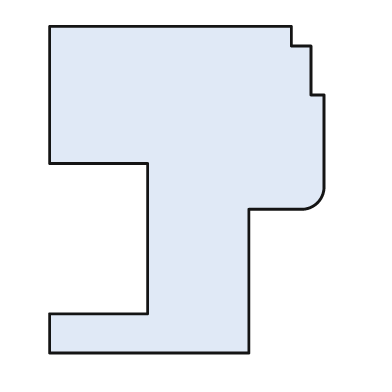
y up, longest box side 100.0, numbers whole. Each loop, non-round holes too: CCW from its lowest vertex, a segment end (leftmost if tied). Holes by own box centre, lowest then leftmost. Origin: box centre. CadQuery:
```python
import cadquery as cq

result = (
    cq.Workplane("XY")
    .moveTo(-42.0, -50.0)
    .lineTo(19.0, -50.0)
    .lineTo(19.0, -6.0)
    .lineTo(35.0, -6.0)
    .threePointArc((40.0, -4.0), (42.0, 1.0))
    .lineTo(42.0, 29.0)
    .lineTo(38.0, 29.0)
    .lineTo(38.0, 44.0)
    .lineTo(32.0, 44.0)
    .lineTo(32.0, 50.0)
    .lineTo(-42.0, 50.0)
    .lineTo(-42.0, 8.0)
    .lineTo(-12.0, 8.0)
    .lineTo(-12.0, -38.0)
    .lineTo(-42.0, -38.0)
    .close()
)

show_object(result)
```